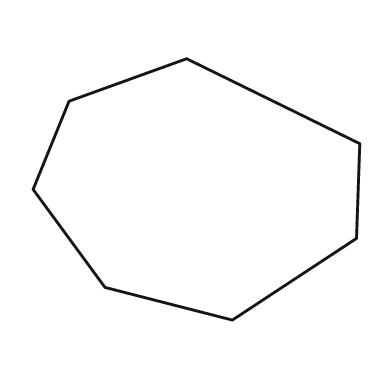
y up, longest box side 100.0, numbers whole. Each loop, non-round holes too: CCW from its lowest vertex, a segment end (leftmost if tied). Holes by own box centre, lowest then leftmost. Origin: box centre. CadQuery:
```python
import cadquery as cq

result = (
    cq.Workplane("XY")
    .moveTo(11.0, -40.0)
    .lineTo(49.0, -15.0)
    .lineTo(50.0, 14.0)
    .lineTo(-3.0, 40.0)
    .lineTo(-39.0, 27.0)
    .lineTo(-50.0, 0.0)
    .lineTo(-28.0, -30.0)
    .close()
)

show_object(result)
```